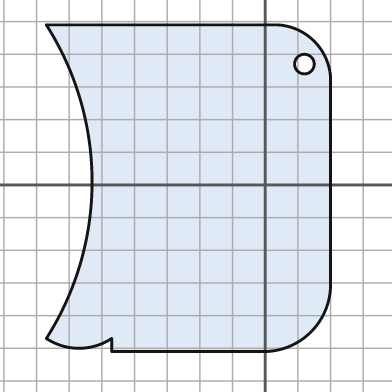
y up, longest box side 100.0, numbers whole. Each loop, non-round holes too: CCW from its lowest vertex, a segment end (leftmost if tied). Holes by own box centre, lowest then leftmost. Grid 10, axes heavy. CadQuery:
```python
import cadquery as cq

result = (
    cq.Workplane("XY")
    .moveTo(-47.0, -51.0)
    .lineTo(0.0, -51.0)
    .threePointArc((14.0, -45.0), (20.0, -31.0))
    .lineTo(20.0, 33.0)
    .threePointArc((15.0, 44.0), (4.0, 49.0))
    .lineTo(-67.0, 49.0)
    .threePointArc((-53.0, 1.0), (-67.0, -47.0))
    .threePointArc((-57.0, -50.0), (-47.0, -47.0))
    .close()
    .moveTo(12.0, 37.0)
    .circle(3.0)
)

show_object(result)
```